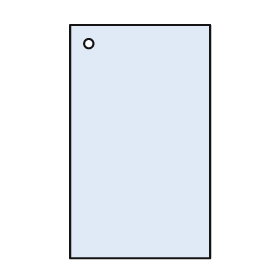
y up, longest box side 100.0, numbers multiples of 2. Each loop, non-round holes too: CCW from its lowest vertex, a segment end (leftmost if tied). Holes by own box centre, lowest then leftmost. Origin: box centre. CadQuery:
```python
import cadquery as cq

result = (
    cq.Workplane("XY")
    .moveTo(-30.0, -50.0)
    .lineTo(30.0, -50.0)
    .lineTo(30.0, 50.0)
    .lineTo(-30.0, 50.0)
    .close()
    .moveTo(-22.0, 42.0)
    .circle(2.0)
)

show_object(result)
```